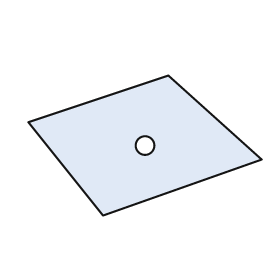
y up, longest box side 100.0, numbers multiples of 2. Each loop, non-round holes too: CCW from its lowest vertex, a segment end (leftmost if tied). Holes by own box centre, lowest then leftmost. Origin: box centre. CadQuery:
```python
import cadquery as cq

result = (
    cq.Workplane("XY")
    .moveTo(-18.0, -30.0)
    .lineTo(50.0, -6.0)
    .lineTo(10.0, 30.0)
    .lineTo(-50.0, 10.0)
    .close()
    .moveTo(0.0, 0.0)
    .circle(4.0)
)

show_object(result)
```